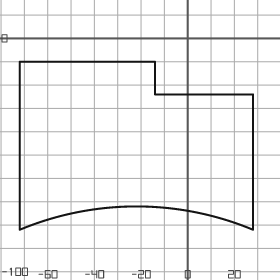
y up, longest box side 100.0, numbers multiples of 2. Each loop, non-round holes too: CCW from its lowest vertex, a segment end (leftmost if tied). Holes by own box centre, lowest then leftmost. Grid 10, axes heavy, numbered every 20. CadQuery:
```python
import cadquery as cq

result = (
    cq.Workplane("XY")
    .moveTo(-72.0, -82.0)
    .threePointArc((-22.0, -72.0), (28.0, -82.0))
    .lineTo(28.0, -24.0)
    .lineTo(-14.0, -24.0)
    .lineTo(-14.0, -10.0)
    .lineTo(-72.0, -10.0)
    .close()
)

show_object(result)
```